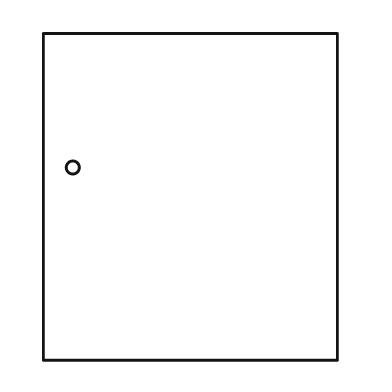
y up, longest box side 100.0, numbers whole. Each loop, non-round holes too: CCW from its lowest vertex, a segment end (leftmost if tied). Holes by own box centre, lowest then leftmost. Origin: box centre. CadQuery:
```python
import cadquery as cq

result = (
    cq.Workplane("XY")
    .moveTo(-45.0, -50.0)
    .lineTo(45.0, -50.0)
    .lineTo(45.0, 50.0)
    .lineTo(-45.0, 50.0)
    .close()
    .moveTo(-36.0, 9.0)
    .circle(2.0)
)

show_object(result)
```